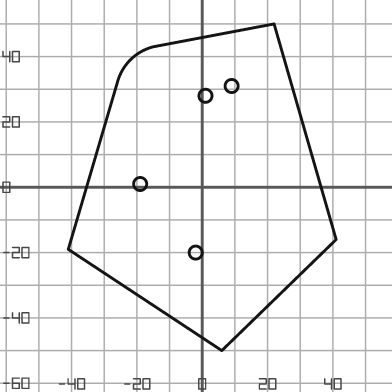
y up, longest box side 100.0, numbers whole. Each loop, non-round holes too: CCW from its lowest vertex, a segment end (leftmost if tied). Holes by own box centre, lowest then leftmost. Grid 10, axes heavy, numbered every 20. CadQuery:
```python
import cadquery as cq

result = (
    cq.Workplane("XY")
    .moveTo(6.0, -50.0)
    .lineTo(41.0, -16.0)
    .lineTo(22.0, 50.0)
    .lineTo(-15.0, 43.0)
    .threePointArc((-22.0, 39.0), (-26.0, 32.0))
    .lineTo(-41.0, -19.0)
    .close()
    .moveTo(-2.0, -20.0)
    .circle(2.0)
    .moveTo(-19.0, 1.0)
    .circle(2.0)
    .moveTo(1.0, 28.0)
    .circle(2.0)
    .moveTo(9.0, 31.0)
    .circle(2.0)
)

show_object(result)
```